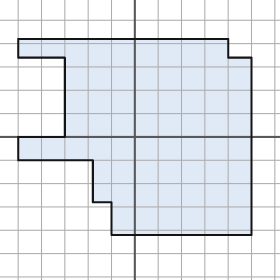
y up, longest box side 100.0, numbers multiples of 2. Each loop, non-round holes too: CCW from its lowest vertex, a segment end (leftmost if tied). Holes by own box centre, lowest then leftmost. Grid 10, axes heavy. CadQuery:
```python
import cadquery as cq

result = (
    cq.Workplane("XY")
    .moveTo(-10.0, -42.0)
    .lineTo(50.0, -42.0)
    .lineTo(50.0, 34.0)
    .lineTo(40.0, 34.0)
    .lineTo(40.0, 42.0)
    .lineTo(-50.0, 42.0)
    .lineTo(-50.0, 34.0)
    .lineTo(-30.0, 34.0)
    .lineTo(-30.0, 0.0)
    .lineTo(-50.0, 0.0)
    .lineTo(-50.0, -10.0)
    .lineTo(-18.0, -10.0)
    .lineTo(-18.0, -28.0)
    .lineTo(-10.0, -28.0)
    .close()
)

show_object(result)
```